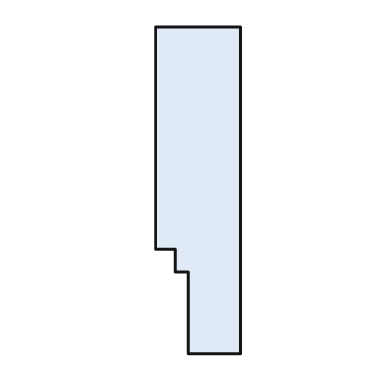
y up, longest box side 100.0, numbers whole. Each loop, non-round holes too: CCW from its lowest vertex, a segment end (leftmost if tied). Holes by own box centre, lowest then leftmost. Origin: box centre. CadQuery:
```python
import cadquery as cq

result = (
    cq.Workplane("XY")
    .moveTo(-3.0, -50.0)
    .lineTo(13.0, -50.0)
    .lineTo(13.0, 50.0)
    .lineTo(-13.0, 50.0)
    .lineTo(-13.0, -18.0)
    .lineTo(-7.0, -18.0)
    .lineTo(-7.0, -25.0)
    .lineTo(-3.0, -25.0)
    .close()
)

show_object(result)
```